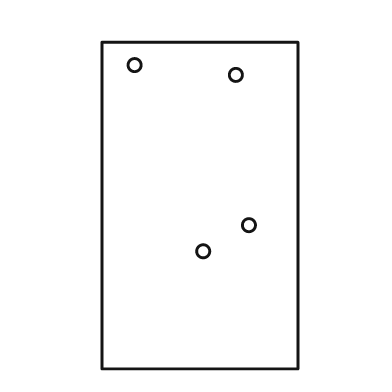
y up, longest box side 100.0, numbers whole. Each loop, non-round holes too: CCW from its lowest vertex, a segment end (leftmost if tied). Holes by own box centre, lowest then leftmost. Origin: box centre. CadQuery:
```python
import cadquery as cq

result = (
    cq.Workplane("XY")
    .moveTo(-30.0, -50.0)
    .lineTo(30.0, -50.0)
    .lineTo(30.0, 50.0)
    .lineTo(-30.0, 50.0)
    .close()
    .moveTo(1.0, -14.0)
    .circle(2.0)
    .moveTo(15.0, -6.0)
    .circle(2.0)
    .moveTo(11.0, 40.0)
    .circle(2.0)
    .moveTo(-20.0, 43.0)
    .circle(2.0)
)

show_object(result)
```